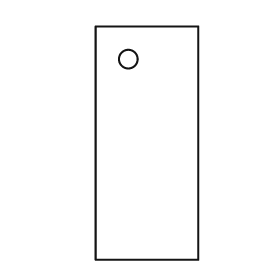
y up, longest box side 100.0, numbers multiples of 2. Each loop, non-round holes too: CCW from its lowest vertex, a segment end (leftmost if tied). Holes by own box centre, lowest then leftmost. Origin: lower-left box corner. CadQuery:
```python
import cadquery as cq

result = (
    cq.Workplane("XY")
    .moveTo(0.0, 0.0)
    .lineTo(44.0, 0.0)
    .lineTo(44.0, 100.0)
    .lineTo(0.0, 100.0)
    .close()
    .moveTo(14.0, 86.0)
    .circle(4.0)
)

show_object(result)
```